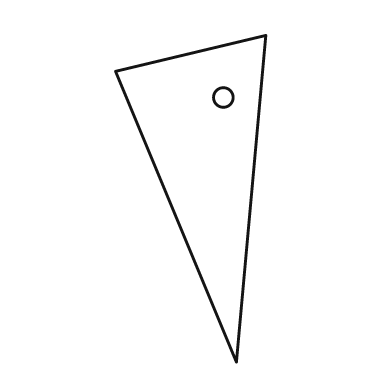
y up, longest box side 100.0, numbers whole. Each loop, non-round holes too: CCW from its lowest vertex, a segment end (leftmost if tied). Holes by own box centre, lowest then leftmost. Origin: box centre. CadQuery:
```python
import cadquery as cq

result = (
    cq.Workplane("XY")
    .moveTo(14.0, -50.0)
    .lineTo(23.0, 50.0)
    .lineTo(-23.0, 39.0)
    .close()
    .moveTo(10.0, 31.0)
    .circle(3.0)
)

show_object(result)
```